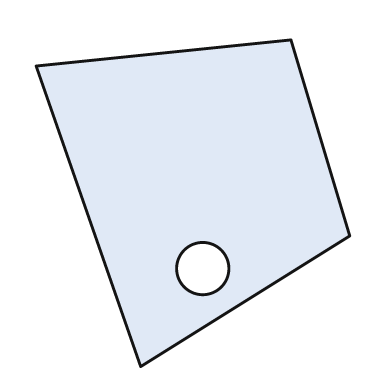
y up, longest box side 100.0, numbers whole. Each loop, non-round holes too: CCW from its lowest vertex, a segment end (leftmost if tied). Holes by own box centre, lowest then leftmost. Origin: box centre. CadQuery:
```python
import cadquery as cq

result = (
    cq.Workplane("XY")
    .moveTo(-16.0, -50.0)
    .lineTo(48.0, -10.0)
    .lineTo(30.0, 50.0)
    .lineTo(-48.0, 42.0)
    .close()
    .moveTo(3.0, -20.0)
    .circle(8.0)
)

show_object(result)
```